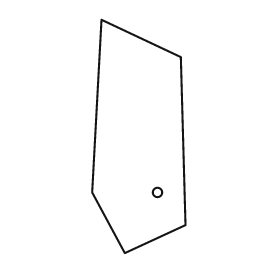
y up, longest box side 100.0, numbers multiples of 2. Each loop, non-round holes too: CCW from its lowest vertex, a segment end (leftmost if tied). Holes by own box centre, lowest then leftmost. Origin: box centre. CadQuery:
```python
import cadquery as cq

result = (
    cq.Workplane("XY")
    .moveTo(-6.0, -50.0)
    .lineTo(20.0, -38.0)
    .lineTo(18.0, 34.0)
    .lineTo(-16.0, 50.0)
    .lineTo(-20.0, -24.0)
    .close()
    .moveTo(8.0, -24.0)
    .circle(2.0)
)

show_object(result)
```